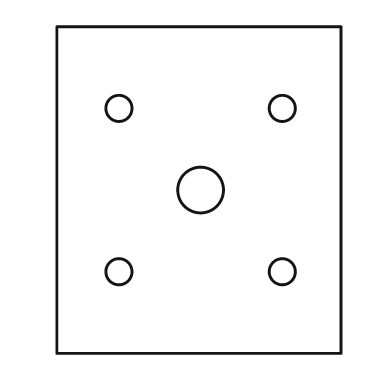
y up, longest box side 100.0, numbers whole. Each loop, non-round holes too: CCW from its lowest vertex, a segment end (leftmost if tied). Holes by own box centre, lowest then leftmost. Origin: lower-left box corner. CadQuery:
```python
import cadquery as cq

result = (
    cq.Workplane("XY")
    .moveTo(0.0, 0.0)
    .lineTo(87.0, 0.0)
    .lineTo(87.0, 100.0)
    .lineTo(0.0, 100.0)
    .close()
    .moveTo(19.0, 25.0)
    .circle(4.0)
    .moveTo(69.0, 25.0)
    .circle(4.0)
    .moveTo(44.0, 50.0)
    .circle(7.0)
    .moveTo(19.0, 75.0)
    .circle(4.0)
    .moveTo(69.0, 75.0)
    .circle(4.0)
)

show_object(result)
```